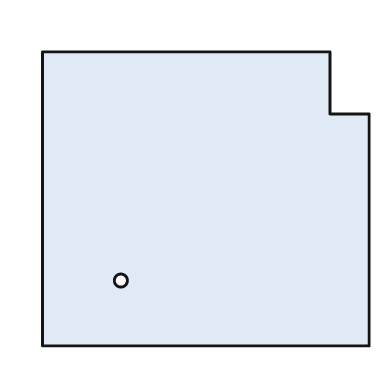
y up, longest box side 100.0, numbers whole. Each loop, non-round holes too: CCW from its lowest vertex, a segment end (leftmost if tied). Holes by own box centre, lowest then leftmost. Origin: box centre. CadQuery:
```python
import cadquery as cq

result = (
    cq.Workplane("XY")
    .moveTo(-50.0, -45.0)
    .lineTo(50.0, -45.0)
    .lineTo(50.0, 26.0)
    .lineTo(38.0, 26.0)
    .lineTo(38.0, 45.0)
    .lineTo(-50.0, 45.0)
    .close()
    .moveTo(-26.0, -25.0)
    .circle(2.0)
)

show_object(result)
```